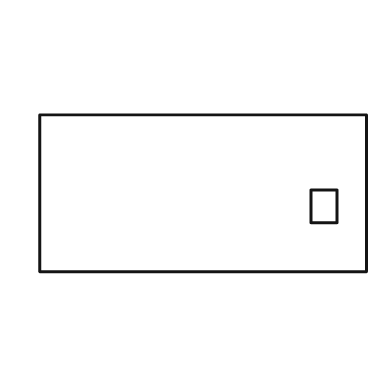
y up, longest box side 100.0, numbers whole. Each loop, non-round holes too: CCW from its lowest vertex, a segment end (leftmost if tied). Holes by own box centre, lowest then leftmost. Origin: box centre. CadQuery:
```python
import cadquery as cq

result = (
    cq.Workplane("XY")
    .moveTo(-50.0, -24.0)
    .lineTo(50.0, -24.0)
    .lineTo(50.0, 24.0)
    .lineTo(-50.0, 24.0)
    .close()
    .moveTo(33.0, -9.0)
    .lineTo(41.0, -9.0)
    .lineTo(41.0, 1.0)
    .lineTo(33.0, 1.0)
    .close()
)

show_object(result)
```